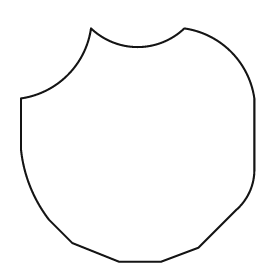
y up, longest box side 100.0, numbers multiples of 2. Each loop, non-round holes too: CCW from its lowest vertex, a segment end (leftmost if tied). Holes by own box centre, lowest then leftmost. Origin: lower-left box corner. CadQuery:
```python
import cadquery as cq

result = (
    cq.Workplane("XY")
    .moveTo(42.0, 0.0)
    .lineTo(60.0, 0.0)
    .lineTo(76.0, 6.0)
    .lineTo(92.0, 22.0)
    .threePointArc((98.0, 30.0), (100.0, 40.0))
    .lineTo(100.0, 70.0)
    .threePointArc((90.0, 90.0), (70.0, 100.0))
    .threePointArc((50.0, 92.0), (30.0, 100.0))
    .threePointArc((20.0, 80.0), (0.0, 70.0))
    .lineTo(0.0, 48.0)
    .threePointArc((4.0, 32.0), (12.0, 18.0))
    .lineTo(22.0, 8.0)
    .close()
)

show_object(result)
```